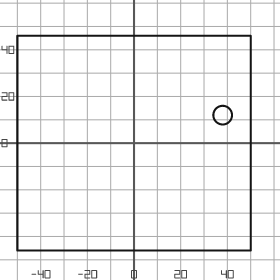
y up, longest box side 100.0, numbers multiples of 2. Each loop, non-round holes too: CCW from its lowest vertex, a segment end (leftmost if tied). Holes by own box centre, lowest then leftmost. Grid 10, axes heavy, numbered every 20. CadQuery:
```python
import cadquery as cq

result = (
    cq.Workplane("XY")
    .moveTo(-50.0, -46.0)
    .lineTo(50.0, -46.0)
    .lineTo(50.0, 46.0)
    .lineTo(-50.0, 46.0)
    .close()
    .moveTo(38.0, 12.0)
    .circle(4.0)
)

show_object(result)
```